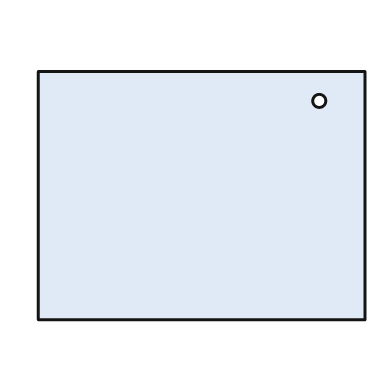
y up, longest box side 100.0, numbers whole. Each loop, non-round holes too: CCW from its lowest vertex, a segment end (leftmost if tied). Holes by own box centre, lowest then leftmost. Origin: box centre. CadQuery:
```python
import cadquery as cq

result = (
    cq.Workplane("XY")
    .moveTo(-50.0, -38.0)
    .lineTo(50.0, -38.0)
    .lineTo(50.0, 38.0)
    .lineTo(-50.0, 38.0)
    .close()
    .moveTo(36.0, 29.0)
    .circle(2.0)
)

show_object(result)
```